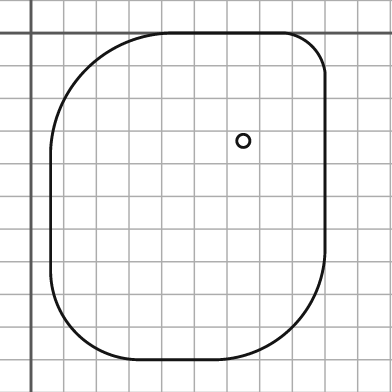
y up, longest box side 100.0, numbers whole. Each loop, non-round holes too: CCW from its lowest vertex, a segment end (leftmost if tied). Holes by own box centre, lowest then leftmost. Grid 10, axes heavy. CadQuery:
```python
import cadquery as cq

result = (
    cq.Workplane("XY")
    .moveTo(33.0, -100.0)
    .lineTo(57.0, -100.0)
    .threePointArc((80.0, -90.0), (90.0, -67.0))
    .lineTo(90.0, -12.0)
    .threePointArc((86.0, -4.0), (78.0, 0.0))
    .lineTo(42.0, 0.0)
    .threePointArc((17.0, -11.0), (6.0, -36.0))
    .lineTo(6.0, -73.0)
    .threePointArc((14.0, -92.0), (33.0, -100.0))
    .close()
    .moveTo(65.0, -33.0)
    .circle(2.0)
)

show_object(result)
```